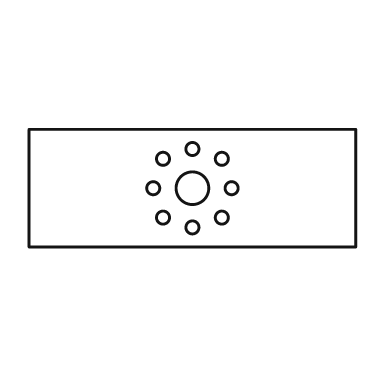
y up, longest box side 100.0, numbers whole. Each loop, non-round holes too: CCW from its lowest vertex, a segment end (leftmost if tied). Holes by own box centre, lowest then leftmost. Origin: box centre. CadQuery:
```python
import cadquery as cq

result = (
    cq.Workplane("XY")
    .moveTo(-50.0, -18.0)
    .lineTo(50.0, -18.0)
    .lineTo(50.0, 18.0)
    .lineTo(-50.0, 18.0)
    .close()
    .moveTo(0.0, -12.0)
    .circle(2.0)
    .moveTo(-9.0, -9.0)
    .circle(2.0)
    .moveTo(9.0, -9.0)
    .circle(2.0)
    .moveTo(-12.0, 0.0)
    .circle(2.0)
    .moveTo(0.0, 0.0)
    .circle(5.0)
    .moveTo(12.0, 0.0)
    .circle(2.0)
    .moveTo(-9.0, 9.0)
    .circle(2.0)
    .moveTo(9.0, 9.0)
    .circle(2.0)
    .moveTo(0.0, 12.0)
    .circle(2.0)
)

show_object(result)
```